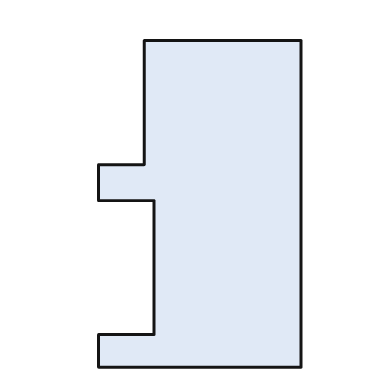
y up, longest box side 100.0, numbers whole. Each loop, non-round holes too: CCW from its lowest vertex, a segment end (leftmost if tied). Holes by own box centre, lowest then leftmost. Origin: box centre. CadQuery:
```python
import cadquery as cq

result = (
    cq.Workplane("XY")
    .moveTo(-31.0, -50.0)
    .lineTo(31.0, -50.0)
    .lineTo(31.0, 50.0)
    .lineTo(-17.0, 50.0)
    .lineTo(-17.0, 12.0)
    .lineTo(-31.0, 12.0)
    .lineTo(-31.0, 1.0)
    .lineTo(-14.0, 1.0)
    .lineTo(-14.0, -40.0)
    .lineTo(-31.0, -40.0)
    .close()
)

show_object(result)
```